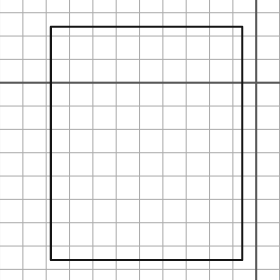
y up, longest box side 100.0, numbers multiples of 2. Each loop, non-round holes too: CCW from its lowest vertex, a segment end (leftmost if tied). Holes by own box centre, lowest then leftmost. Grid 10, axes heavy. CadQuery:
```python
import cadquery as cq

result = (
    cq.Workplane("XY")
    .moveTo(-88.0, -76.0)
    .lineTo(-6.0, -76.0)
    .lineTo(-6.0, 24.0)
    .lineTo(-88.0, 24.0)
    .close()
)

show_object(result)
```